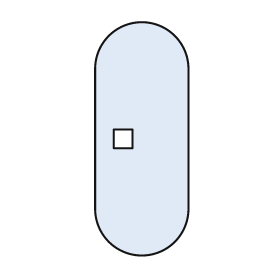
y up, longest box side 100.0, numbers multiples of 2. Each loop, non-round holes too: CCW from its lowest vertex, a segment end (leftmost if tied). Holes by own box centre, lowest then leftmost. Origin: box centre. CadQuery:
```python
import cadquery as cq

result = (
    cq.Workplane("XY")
    .moveTo(-20.0, -30.0)
    .threePointArc((0.0, -50.0), (20.0, -30.0))
    .lineTo(20.0, 30.0)
    .threePointArc((0.0, 50.0), (-20.0, 30.0))
    .close()
    .moveTo(-12.0, -4.0)
    .lineTo(-4.0, -4.0)
    .lineTo(-4.0, 4.0)
    .lineTo(-12.0, 4.0)
    .close()
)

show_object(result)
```